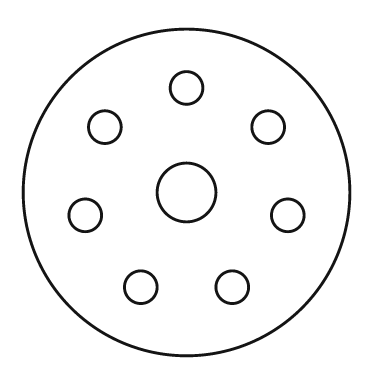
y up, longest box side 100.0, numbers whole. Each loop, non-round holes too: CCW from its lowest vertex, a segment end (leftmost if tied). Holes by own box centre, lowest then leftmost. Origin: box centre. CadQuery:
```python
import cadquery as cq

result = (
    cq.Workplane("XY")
    .moveTo(0.0, 0.0)
    .circle(50.0)
    .moveTo(-14.0, -29.0)
    .circle(5.0)
    .moveTo(14.0, -29.0)
    .circle(5.0)
    .moveTo(-31.0, -7.0)
    .circle(5.0)
    .moveTo(31.0, -7.0)
    .circle(5.0)
    .moveTo(0.0, 0.0)
    .circle(9.0)
    .moveTo(-25.0, 20.0)
    .circle(5.0)
    .moveTo(25.0, 20.0)
    .circle(5.0)
    .moveTo(0.0, 32.0)
    .circle(5.0)
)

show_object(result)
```